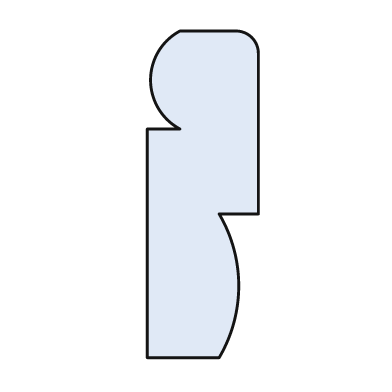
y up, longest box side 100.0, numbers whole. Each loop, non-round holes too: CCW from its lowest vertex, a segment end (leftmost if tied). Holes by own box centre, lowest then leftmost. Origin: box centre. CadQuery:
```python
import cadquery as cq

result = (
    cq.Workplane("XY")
    .moveTo(-17.0, -50.0)
    .lineTo(5.0, -50.0)
    .threePointArc((11.0, -28.0), (5.0, -6.0))
    .lineTo(17.0, -6.0)
    .lineTo(17.0, 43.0)
    .threePointArc((15.0, 48.0), (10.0, 50.0))
    .lineTo(-7.0, 50.0)
    .threePointArc((-16.0, 35.0), (-7.0, 20.0))
    .lineTo(-17.0, 20.0)
    .close()
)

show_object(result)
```